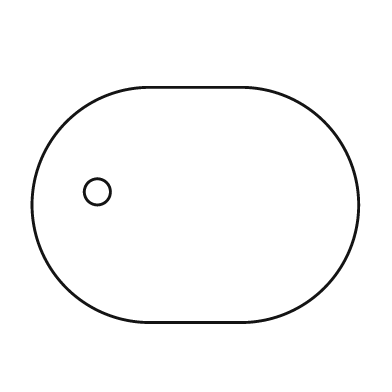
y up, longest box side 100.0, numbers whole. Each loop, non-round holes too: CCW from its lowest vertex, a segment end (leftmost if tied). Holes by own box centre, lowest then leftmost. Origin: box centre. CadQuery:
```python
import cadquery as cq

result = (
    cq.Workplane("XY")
    .moveTo(-14.0, -36.0)
    .lineTo(14.0, -36.0)
    .threePointArc((50.0, 0.0), (14.0, 36.0))
    .lineTo(-14.0, 36.0)
    .threePointArc((-50.0, 0.0), (-14.0, -36.0))
    .close()
    .moveTo(-30.0, 4.0)
    .circle(4.0)
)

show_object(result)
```